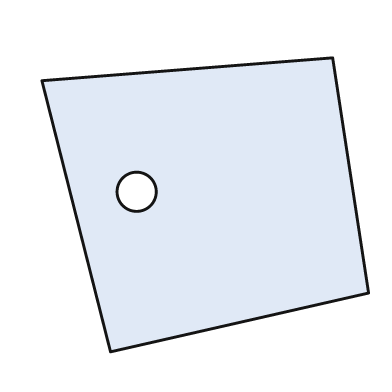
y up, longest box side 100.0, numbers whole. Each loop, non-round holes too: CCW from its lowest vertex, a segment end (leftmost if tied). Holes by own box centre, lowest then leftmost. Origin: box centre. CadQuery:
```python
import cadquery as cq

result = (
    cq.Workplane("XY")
    .moveTo(-29.0, -45.0)
    .lineTo(50.0, -27.0)
    .lineTo(39.0, 45.0)
    .lineTo(-50.0, 38.0)
    .close()
    .moveTo(-21.0, 4.0)
    .circle(6.0)
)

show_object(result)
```